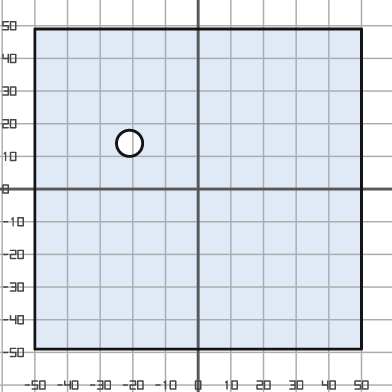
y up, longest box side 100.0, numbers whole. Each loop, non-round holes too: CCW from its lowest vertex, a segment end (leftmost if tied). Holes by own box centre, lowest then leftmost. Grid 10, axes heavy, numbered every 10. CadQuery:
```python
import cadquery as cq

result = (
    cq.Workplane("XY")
    .moveTo(-50.0, -49.0)
    .lineTo(50.0, -49.0)
    .lineTo(50.0, 49.0)
    .lineTo(-50.0, 49.0)
    .close()
    .moveTo(-21.0, 14.0)
    .circle(4.0)
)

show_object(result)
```